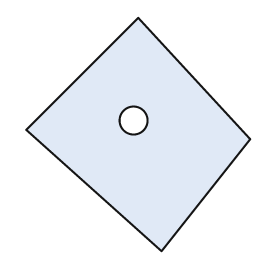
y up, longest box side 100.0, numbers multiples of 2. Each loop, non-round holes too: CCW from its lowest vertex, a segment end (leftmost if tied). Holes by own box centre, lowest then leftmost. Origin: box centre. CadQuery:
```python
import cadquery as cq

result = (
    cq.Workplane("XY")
    .moveTo(10.0, -50.0)
    .lineTo(48.0, -2.0)
    .lineTo(0.0, 50.0)
    .lineTo(-48.0, 2.0)
    .close()
    .moveTo(-2.0, 6.0)
    .circle(6.0)
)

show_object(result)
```